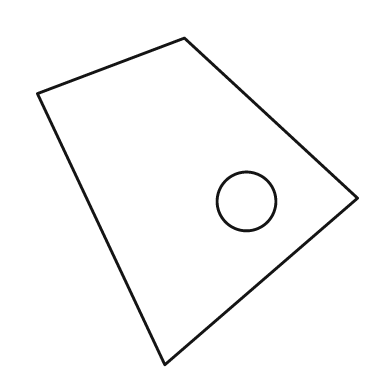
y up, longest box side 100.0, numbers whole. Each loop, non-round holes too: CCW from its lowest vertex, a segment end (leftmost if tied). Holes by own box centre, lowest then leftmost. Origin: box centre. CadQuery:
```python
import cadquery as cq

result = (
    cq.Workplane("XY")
    .moveTo(-10.0, -50.0)
    .lineTo(49.0, 1.0)
    .lineTo(-4.0, 50.0)
    .lineTo(-49.0, 33.0)
    .close()
    .moveTo(15.0, 0.0)
    .circle(9.0)
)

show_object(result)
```